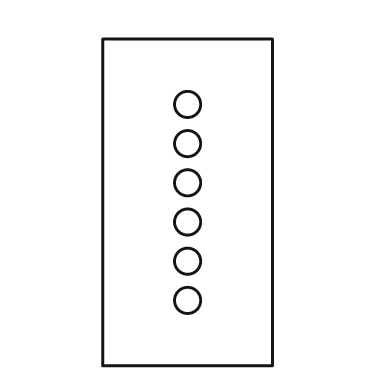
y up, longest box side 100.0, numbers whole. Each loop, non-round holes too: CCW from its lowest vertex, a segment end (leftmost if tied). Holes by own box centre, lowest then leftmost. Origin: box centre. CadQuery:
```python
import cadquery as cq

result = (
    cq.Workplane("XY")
    .moveTo(-26.0, -50.0)
    .lineTo(26.0, -50.0)
    .lineTo(26.0, 50.0)
    .lineTo(-26.0, 50.0)
    .close()
    .moveTo(0.0, -30.0)
    .circle(4.0)
    .moveTo(0.0, -18.0)
    .circle(4.0)
    .moveTo(0.0, -6.0)
    .circle(4.0)
    .moveTo(0.0, 6.0)
    .circle(4.0)
    .moveTo(0.0, 18.0)
    .circle(4.0)
    .moveTo(0.0, 30.0)
    .circle(4.0)
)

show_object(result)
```